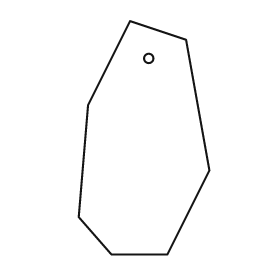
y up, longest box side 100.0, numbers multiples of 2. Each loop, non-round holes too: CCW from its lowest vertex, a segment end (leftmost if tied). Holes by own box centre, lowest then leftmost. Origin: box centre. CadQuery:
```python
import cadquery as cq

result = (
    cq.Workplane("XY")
    .moveTo(-14.0, -50.0)
    .lineTo(10.0, -50.0)
    .lineTo(28.0, -14.0)
    .lineTo(18.0, 42.0)
    .lineTo(-6.0, 50.0)
    .lineTo(-24.0, 14.0)
    .lineTo(-28.0, -34.0)
    .close()
    .moveTo(2.0, 34.0)
    .circle(2.0)
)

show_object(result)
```